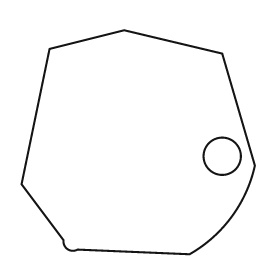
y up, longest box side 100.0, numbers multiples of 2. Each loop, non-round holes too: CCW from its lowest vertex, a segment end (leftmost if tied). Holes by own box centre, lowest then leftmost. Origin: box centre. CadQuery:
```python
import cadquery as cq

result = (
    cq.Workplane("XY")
    .moveTo(22.0, -48.0)
    .threePointArc((40.0, -32.0), (50.0, -10.0))
    .lineTo(36.0, 38.0)
    .lineTo(-6.0, 48.0)
    .lineTo(-38.0, 40.0)
    .lineTo(-50.0, -18.0)
    .lineTo(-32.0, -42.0)
    .threePointArc((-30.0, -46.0), (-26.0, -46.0))
    .close()
    .moveTo(36.0, -6.0)
    .circle(8.0)
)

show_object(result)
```